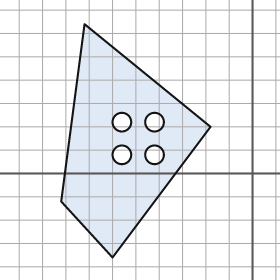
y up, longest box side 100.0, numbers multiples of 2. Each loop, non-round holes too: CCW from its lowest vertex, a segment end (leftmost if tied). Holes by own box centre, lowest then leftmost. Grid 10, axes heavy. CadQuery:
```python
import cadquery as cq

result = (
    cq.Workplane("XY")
    .moveTo(-60.0, -36.0)
    .lineTo(-18.0, 20.0)
    .lineTo(-72.0, 64.0)
    .lineTo(-82.0, -12.0)
    .close()
    .moveTo(-56.0, 8.0)
    .circle(4.0)
    .moveTo(-42.0, 8.0)
    .circle(4.0)
    .moveTo(-56.0, 22.0)
    .circle(4.0)
    .moveTo(-42.0, 22.0)
    .circle(4.0)
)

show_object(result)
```